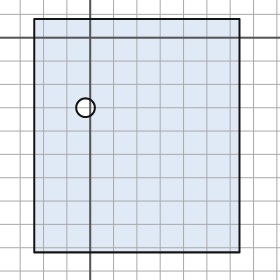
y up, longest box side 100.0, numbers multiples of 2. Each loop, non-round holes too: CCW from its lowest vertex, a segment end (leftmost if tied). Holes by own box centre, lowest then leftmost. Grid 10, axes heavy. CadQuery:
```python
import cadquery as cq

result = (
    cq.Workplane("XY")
    .moveTo(-24.0, -92.0)
    .lineTo(64.0, -92.0)
    .lineTo(64.0, 8.0)
    .lineTo(-24.0, 8.0)
    .close()
    .moveTo(-2.0, -30.0)
    .circle(4.0)
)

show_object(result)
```